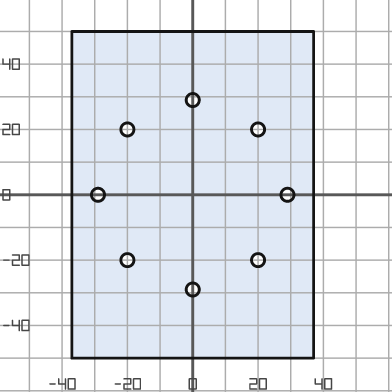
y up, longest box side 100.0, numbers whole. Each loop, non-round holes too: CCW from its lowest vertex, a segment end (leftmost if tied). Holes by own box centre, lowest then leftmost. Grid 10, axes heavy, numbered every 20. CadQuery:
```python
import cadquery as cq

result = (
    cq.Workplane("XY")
    .moveTo(-37.0, -50.0)
    .lineTo(37.0, -50.0)
    .lineTo(37.0, 50.0)
    .lineTo(-37.0, 50.0)
    .close()
    .moveTo(0.0, -29.0)
    .circle(2.0)
    .moveTo(-20.0, -20.0)
    .circle(2.0)
    .moveTo(20.0, -20.0)
    .circle(2.0)
    .moveTo(-29.0, 0.0)
    .circle(2.0)
    .moveTo(29.0, 0.0)
    .circle(2.0)
    .moveTo(-20.0, 20.0)
    .circle(2.0)
    .moveTo(20.0, 20.0)
    .circle(2.0)
    .moveTo(0.0, 29.0)
    .circle(2.0)
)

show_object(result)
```